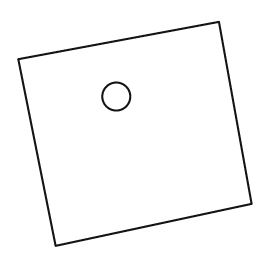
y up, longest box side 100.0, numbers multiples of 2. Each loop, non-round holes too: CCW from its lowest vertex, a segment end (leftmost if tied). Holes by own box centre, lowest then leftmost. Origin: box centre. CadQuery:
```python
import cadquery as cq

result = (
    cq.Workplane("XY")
    .moveTo(-34.0, -48.0)
    .lineTo(50.0, -30.0)
    .lineTo(36.0, 48.0)
    .lineTo(-50.0, 32.0)
    .close()
    .moveTo(-8.0, 16.0)
    .circle(6.0)
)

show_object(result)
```